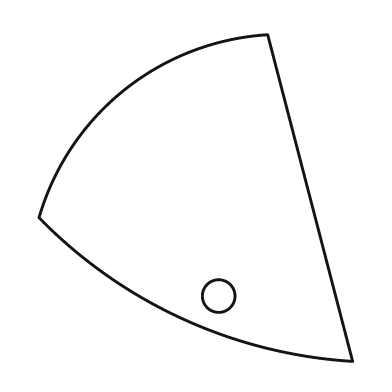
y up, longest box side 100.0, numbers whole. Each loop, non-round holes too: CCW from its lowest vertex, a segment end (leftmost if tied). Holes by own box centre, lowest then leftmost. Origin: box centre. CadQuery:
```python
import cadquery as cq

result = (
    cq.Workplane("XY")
    .moveTo(48.0, -50.0)
    .lineTo(22.0, 50.0)
    .threePointArc((-22.0, 33.0), (-48.0, -6.0))
    .threePointArc((-4.0, -37.0), (48.0, -50.0))
    .close()
    .moveTo(7.0, -30.0)
    .circle(5.0)
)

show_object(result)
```